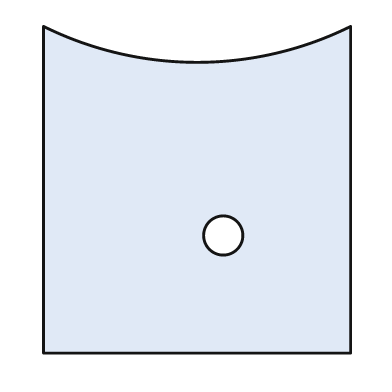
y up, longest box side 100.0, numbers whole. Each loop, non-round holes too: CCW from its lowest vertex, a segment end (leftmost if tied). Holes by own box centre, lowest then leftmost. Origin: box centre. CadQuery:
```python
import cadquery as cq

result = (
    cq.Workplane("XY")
    .moveTo(-47.0, -50.0)
    .lineTo(47.0, -50.0)
    .lineTo(47.0, 50.0)
    .threePointArc((0.0, 39.0), (-47.0, 50.0))
    .close()
    .moveTo(8.0, -14.0)
    .circle(6.0)
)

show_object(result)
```